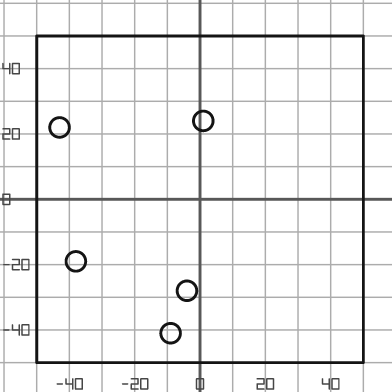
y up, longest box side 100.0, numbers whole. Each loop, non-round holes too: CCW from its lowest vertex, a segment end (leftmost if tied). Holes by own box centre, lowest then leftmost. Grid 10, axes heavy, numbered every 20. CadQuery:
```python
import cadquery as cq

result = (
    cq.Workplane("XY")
    .moveTo(-50.0, -50.0)
    .lineTo(50.0, -50.0)
    .lineTo(50.0, 50.0)
    .lineTo(-50.0, 50.0)
    .close()
    .moveTo(-9.0, -41.0)
    .circle(3.0)
    .moveTo(-4.0, -28.0)
    .circle(3.0)
    .moveTo(-38.0, -19.0)
    .circle(3.0)
    .moveTo(-43.0, 22.0)
    .circle(3.0)
    .moveTo(1.0, 24.0)
    .circle(3.0)
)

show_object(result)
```